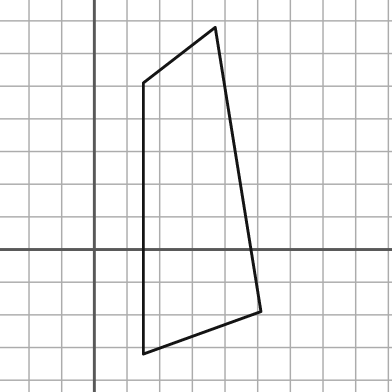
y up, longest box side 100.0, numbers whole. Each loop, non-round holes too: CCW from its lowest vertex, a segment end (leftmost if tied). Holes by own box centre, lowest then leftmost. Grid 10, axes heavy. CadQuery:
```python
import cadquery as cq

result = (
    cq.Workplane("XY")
    .moveTo(15.0, -32.0)
    .lineTo(51.0, -19.0)
    .lineTo(37.0, 68.0)
    .lineTo(15.0, 51.0)
    .close()
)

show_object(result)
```